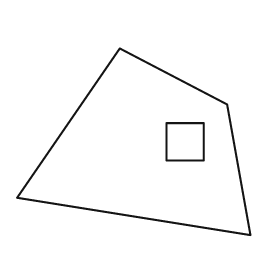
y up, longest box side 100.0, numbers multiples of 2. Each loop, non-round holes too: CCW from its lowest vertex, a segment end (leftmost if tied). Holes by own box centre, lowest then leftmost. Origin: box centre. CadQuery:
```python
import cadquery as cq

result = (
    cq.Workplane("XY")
    .moveTo(50.0, -40.0)
    .lineTo(40.0, 16.0)
    .lineTo(-6.0, 40.0)
    .lineTo(-50.0, -24.0)
    .close()
    .moveTo(14.0, -8.0)
    .lineTo(30.0, -8.0)
    .lineTo(30.0, 8.0)
    .lineTo(14.0, 8.0)
    .close()
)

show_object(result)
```